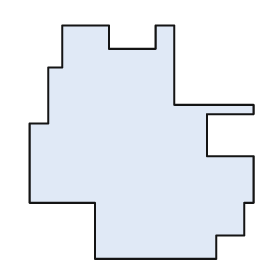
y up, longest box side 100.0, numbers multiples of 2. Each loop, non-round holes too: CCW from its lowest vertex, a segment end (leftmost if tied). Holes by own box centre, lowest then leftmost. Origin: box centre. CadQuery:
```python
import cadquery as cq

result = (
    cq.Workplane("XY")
    .moveTo(-20.0, -50.0)
    .lineTo(32.0, -50.0)
    .lineTo(32.0, -40.0)
    .lineTo(44.0, -40.0)
    .lineTo(44.0, -26.0)
    .lineTo(48.0, -26.0)
    .lineTo(48.0, -6.0)
    .lineTo(28.0, -6.0)
    .lineTo(28.0, 12.0)
    .lineTo(48.0, 12.0)
    .lineTo(48.0, 16.0)
    .lineTo(14.0, 16.0)
    .lineTo(14.0, 50.0)
    .lineTo(6.0, 50.0)
    .lineTo(6.0, 40.0)
    .lineTo(-14.0, 40.0)
    .lineTo(-14.0, 50.0)
    .lineTo(-34.0, 50.0)
    .lineTo(-34.0, 32.0)
    .lineTo(-40.0, 32.0)
    .lineTo(-40.0, 8.0)
    .lineTo(-48.0, 8.0)
    .lineTo(-48.0, -26.0)
    .lineTo(-20.0, -26.0)
    .close()
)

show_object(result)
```